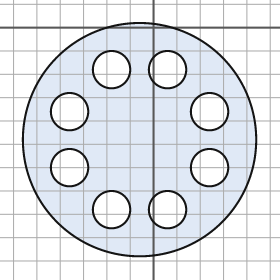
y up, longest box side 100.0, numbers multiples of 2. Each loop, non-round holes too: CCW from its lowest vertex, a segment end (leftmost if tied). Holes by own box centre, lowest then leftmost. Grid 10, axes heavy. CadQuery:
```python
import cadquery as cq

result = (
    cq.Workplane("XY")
    .moveTo(-6.0, -48.0)
    .circle(50.0)
    .moveTo(-18.0, -78.0)
    .circle(8.0)
    .moveTo(6.0, -78.0)
    .circle(8.0)
    .moveTo(-36.0, -60.0)
    .circle(8.0)
    .moveTo(24.0, -60.0)
    .circle(8.0)
    .moveTo(-36.0, -36.0)
    .circle(8.0)
    .moveTo(24.0, -36.0)
    .circle(8.0)
    .moveTo(-18.0, -18.0)
    .circle(8.0)
    .moveTo(6.0, -18.0)
    .circle(8.0)
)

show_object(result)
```